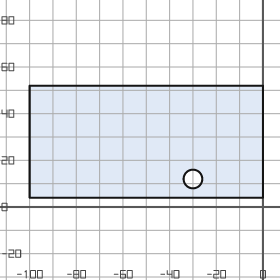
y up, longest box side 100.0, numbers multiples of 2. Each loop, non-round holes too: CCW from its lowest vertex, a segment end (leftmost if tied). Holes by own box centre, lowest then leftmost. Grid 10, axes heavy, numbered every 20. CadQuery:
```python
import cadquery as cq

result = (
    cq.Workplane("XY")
    .moveTo(-100.0, 4.0)
    .lineTo(0.0, 4.0)
    .lineTo(0.0, 52.0)
    .lineTo(-100.0, 52.0)
    .close()
    .moveTo(-30.0, 12.0)
    .circle(4.0)
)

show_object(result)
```